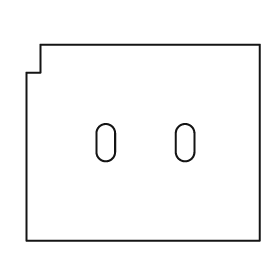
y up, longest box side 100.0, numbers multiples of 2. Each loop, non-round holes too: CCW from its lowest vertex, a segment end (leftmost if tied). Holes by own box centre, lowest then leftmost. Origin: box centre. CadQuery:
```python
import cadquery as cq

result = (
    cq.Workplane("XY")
    .moveTo(-50.0, -42.0)
    .lineTo(50.0, -42.0)
    .lineTo(50.0, 42.0)
    .lineTo(-44.0, 42.0)
    .lineTo(-44.0, 30.0)
    .lineTo(-50.0, 30.0)
    .close()
    .moveTo(-20.0, -4.0)
    .threePointArc((-16.0, -8.0), (-12.0, -4.0))
    .lineTo(-12.0, 4.0)
    .threePointArc((-16.0, 8.0), (-20.0, 4.0))
    .close()
    .moveTo(14.0, -4.0)
    .threePointArc((18.0, -8.0), (22.0, -4.0))
    .lineTo(22.0, 4.0)
    .threePointArc((18.0, 8.0), (14.0, 4.0))
    .close()
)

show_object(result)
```